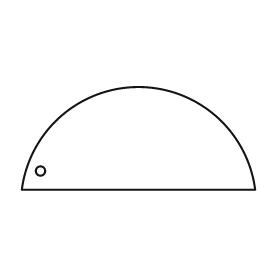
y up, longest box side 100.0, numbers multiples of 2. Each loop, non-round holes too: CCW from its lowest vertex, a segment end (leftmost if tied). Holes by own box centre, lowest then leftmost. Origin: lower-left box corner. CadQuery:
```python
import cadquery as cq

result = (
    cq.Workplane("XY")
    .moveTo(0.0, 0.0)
    .lineTo(100.0, 0.0)
    .threePointArc((50.0, 44.0), (0.0, 0.0))
    .close()
    .moveTo(8.0, 8.0)
    .circle(2.0)
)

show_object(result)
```